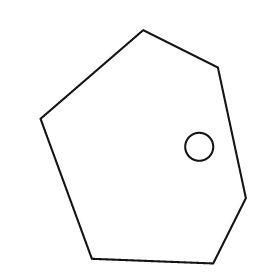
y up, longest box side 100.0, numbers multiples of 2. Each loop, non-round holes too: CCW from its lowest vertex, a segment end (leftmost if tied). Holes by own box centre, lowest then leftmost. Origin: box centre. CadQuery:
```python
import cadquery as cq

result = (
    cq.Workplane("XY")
    .moveTo(30.0, -50.0)
    .lineTo(44.0, -22.0)
    .lineTo(32.0, 34.0)
    .lineTo(0.0, 50.0)
    .lineTo(-44.0, 12.0)
    .lineTo(-22.0, -48.0)
    .close()
    .moveTo(24.0, 0.0)
    .circle(6.0)
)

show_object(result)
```